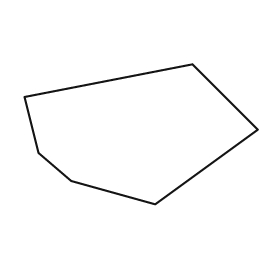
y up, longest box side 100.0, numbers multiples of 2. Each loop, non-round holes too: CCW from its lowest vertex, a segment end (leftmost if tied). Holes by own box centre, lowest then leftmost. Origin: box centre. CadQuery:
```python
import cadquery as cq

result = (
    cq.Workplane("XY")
    .moveTo(6.0, -30.0)
    .lineTo(50.0, 2.0)
    .lineTo(22.0, 30.0)
    .lineTo(-50.0, 16.0)
    .lineTo(-44.0, -8.0)
    .lineTo(-30.0, -20.0)
    .close()
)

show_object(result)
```